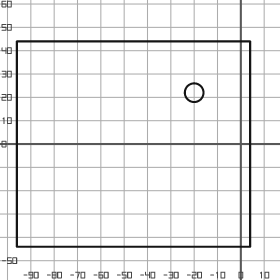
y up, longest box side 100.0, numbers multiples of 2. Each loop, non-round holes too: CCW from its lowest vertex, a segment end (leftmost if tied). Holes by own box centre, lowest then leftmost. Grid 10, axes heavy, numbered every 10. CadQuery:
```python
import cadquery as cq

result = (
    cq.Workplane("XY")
    .moveTo(-96.0, -44.0)
    .lineTo(4.0, -44.0)
    .lineTo(4.0, 44.0)
    .lineTo(-96.0, 44.0)
    .close()
    .moveTo(-20.0, 22.0)
    .circle(4.0)
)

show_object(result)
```